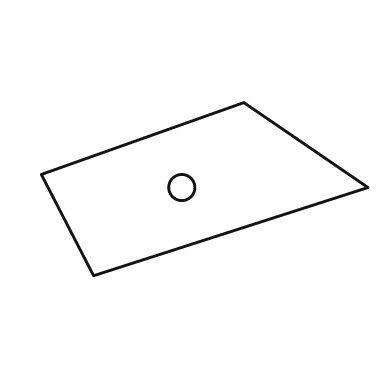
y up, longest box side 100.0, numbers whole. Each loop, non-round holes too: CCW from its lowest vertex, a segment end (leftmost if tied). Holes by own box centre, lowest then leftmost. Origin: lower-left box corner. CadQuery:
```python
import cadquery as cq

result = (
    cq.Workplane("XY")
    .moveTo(16.0, 0.0)
    .lineTo(100.0, 27.0)
    .lineTo(62.0, 53.0)
    .lineTo(0.0, 31.0)
    .close()
    .moveTo(43.0, 27.0)
    .circle(4.0)
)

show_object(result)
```